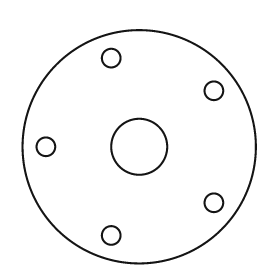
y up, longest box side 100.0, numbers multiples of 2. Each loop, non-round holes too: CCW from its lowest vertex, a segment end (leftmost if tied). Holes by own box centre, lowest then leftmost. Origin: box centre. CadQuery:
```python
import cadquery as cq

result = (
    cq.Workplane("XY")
    .moveTo(0.0, 0.0)
    .circle(50.0)
    .moveTo(-12.0, -38.0)
    .circle(4.0)
    .moveTo(32.0, -24.0)
    .circle(4.0)
    .moveTo(-40.0, 0.0)
    .circle(4.0)
    .moveTo(0.0, 0.0)
    .circle(12.0)
    .moveTo(32.0, 24.0)
    .circle(4.0)
    .moveTo(-12.0, 38.0)
    .circle(4.0)
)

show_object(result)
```